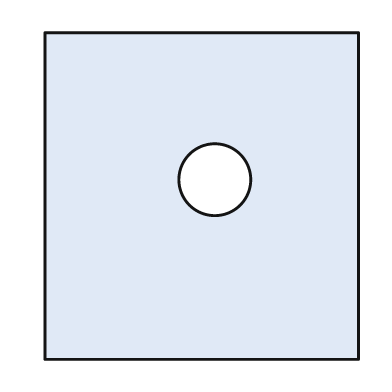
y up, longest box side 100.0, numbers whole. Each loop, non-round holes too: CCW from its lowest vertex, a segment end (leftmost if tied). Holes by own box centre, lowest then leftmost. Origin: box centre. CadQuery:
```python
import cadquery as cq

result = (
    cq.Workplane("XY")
    .moveTo(-48.0, -50.0)
    .lineTo(48.0, -50.0)
    .lineTo(48.0, 50.0)
    .lineTo(-48.0, 50.0)
    .close()
    .moveTo(4.0, 5.0)
    .circle(11.0)
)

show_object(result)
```